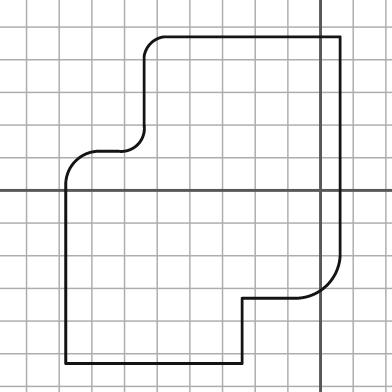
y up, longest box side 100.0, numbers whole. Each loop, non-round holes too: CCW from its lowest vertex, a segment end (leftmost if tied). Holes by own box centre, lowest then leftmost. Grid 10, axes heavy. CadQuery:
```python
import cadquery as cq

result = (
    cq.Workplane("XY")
    .moveTo(-78.0, -53.0)
    .lineTo(-24.0, -53.0)
    .lineTo(-24.0, -33.0)
    .lineTo(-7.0, -33.0)
    .threePointArc((2.0, -29.0), (6.0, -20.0))
    .lineTo(6.0, 47.0)
    .lineTo(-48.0, 47.0)
    .threePointArc((-52.0, 45.0), (-54.0, 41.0))
    .lineTo(-54.0, 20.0)
    .threePointArc((-56.0, 14.0), (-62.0, 12.0))
    .lineTo(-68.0, 12.0)
    .threePointArc((-75.0, 9.0), (-78.0, 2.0))
    .close()
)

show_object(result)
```